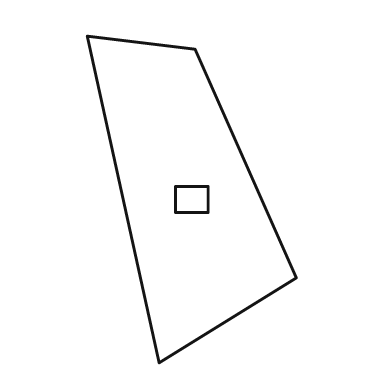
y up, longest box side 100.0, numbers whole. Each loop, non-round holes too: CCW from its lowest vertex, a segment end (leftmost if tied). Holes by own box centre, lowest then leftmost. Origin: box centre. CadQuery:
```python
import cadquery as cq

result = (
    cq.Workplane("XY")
    .moveTo(-10.0, -50.0)
    .lineTo(32.0, -24.0)
    .lineTo(1.0, 46.0)
    .lineTo(-32.0, 50.0)
    .close()
    .moveTo(-5.0, -4.0)
    .lineTo(5.0, -4.0)
    .lineTo(5.0, 4.0)
    .lineTo(-5.0, 4.0)
    .close()
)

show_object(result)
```